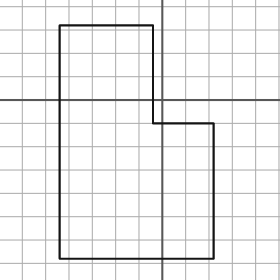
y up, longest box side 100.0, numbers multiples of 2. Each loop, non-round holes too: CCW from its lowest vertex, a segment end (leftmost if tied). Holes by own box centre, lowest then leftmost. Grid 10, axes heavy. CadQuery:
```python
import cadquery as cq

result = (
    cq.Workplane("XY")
    .moveTo(-44.0, -68.0)
    .lineTo(22.0, -68.0)
    .lineTo(22.0, -10.0)
    .lineTo(-4.0, -10.0)
    .lineTo(-4.0, 32.0)
    .lineTo(-44.0, 32.0)
    .close()
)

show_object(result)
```